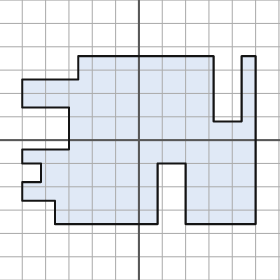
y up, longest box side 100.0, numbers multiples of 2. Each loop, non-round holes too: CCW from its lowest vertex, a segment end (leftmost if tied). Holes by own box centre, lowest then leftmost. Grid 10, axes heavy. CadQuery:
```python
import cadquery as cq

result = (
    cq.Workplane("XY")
    .moveTo(-36.0, -36.0)
    .lineTo(8.0, -36.0)
    .lineTo(8.0, -10.0)
    .lineTo(20.0, -10.0)
    .lineTo(20.0, -36.0)
    .lineTo(50.0, -36.0)
    .lineTo(50.0, 36.0)
    .lineTo(44.0, 36.0)
    .lineTo(44.0, 8.0)
    .lineTo(32.0, 8.0)
    .lineTo(32.0, 36.0)
    .lineTo(-26.0, 36.0)
    .lineTo(-26.0, 26.0)
    .lineTo(-50.0, 26.0)
    .lineTo(-50.0, 14.0)
    .lineTo(-30.0, 14.0)
    .lineTo(-30.0, -4.0)
    .lineTo(-50.0, -4.0)
    .lineTo(-50.0, -10.0)
    .lineTo(-42.0, -10.0)
    .lineTo(-42.0, -18.0)
    .lineTo(-50.0, -18.0)
    .lineTo(-50.0, -26.0)
    .lineTo(-36.0, -26.0)
    .close()
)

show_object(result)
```